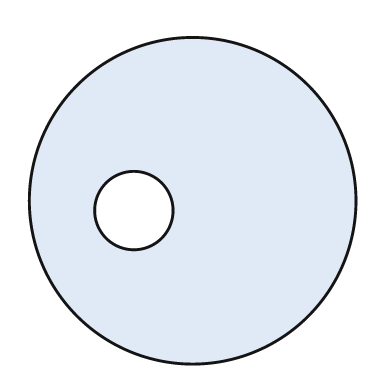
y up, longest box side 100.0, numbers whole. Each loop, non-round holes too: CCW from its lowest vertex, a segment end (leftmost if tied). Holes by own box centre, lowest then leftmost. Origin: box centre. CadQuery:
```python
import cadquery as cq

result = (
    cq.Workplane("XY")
    .moveTo(0.0, 0.0)
    .circle(50.0)
    .moveTo(-18.0, -3.0)
    .circle(12.0)
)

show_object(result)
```